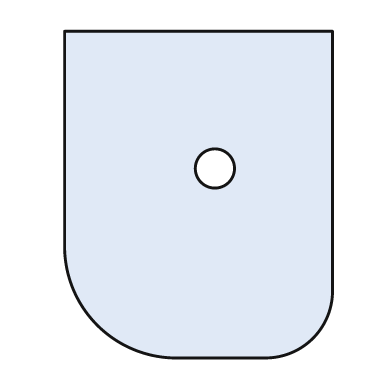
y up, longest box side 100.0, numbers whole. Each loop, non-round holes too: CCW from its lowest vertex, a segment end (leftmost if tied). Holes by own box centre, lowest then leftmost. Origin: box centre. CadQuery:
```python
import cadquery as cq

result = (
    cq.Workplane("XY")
    .moveTo(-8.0, -50.0)
    .lineTo(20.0, -50.0)
    .threePointArc((35.0, -44.0), (41.0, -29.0))
    .lineTo(41.0, 50.0)
    .lineTo(-41.0, 50.0)
    .lineTo(-41.0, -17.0)
    .threePointArc((-31.0, -40.0), (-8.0, -50.0))
    .close()
    .moveTo(5.0, 8.0)
    .circle(6.0)
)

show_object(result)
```